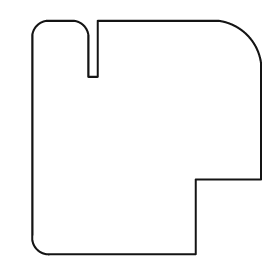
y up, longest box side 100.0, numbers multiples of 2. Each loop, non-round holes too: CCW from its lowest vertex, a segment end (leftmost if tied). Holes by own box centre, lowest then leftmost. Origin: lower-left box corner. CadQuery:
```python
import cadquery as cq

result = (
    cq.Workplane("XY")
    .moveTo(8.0, 0.0)
    .lineTo(70.0, 0.0)
    .lineTo(70.0, 32.0)
    .lineTo(98.0, 32.0)
    .lineTo(98.0, 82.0)
    .threePointArc((92.0, 94.0), (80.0, 100.0))
    .lineTo(28.0, 100.0)
    .lineTo(28.0, 76.0)
    .lineTo(24.0, 76.0)
    .lineTo(24.0, 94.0)
    .threePointArc((22.0, 98.0), (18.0, 100.0))
    .lineTo(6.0, 100.0)
    .threePointArc((2.0, 98.0), (0.0, 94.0))
    .lineTo(0.0, 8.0)
    .threePointArc((2.0, 2.0), (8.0, 0.0))
    .close()
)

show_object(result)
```